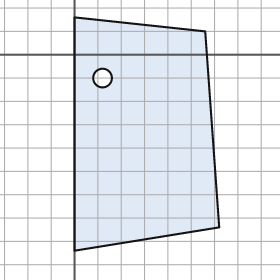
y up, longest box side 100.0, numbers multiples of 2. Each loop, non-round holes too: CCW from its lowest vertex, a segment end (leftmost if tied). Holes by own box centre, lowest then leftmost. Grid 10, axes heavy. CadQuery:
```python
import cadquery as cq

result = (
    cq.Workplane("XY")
    .moveTo(0.0, -84.0)
    .lineTo(62.0, -74.0)
    .lineTo(56.0, 10.0)
    .lineTo(0.0, 16.0)
    .close()
    .moveTo(12.0, -10.0)
    .circle(4.0)
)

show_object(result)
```